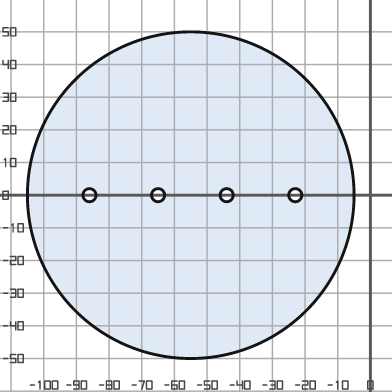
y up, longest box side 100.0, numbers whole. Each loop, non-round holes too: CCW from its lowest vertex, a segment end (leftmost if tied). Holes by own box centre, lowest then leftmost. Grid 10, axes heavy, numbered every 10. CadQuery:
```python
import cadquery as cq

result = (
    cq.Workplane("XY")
    .moveTo(-55.0, 0.0)
    .circle(50.0)
    .moveTo(-86.0, 0.0)
    .circle(2.0)
    .moveTo(-65.0, 0.0)
    .circle(2.0)
    .moveTo(-44.0, 0.0)
    .circle(2.0)
    .moveTo(-23.0, 0.0)
    .circle(2.0)
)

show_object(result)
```